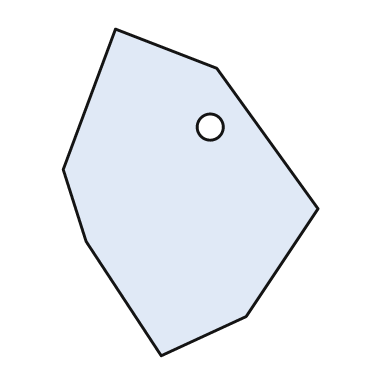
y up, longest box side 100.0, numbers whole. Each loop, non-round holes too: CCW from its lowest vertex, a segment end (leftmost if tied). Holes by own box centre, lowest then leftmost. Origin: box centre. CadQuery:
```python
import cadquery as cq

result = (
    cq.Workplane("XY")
    .moveTo(-9.0, -50.0)
    .lineTo(17.0, -38.0)
    .lineTo(39.0, -5.0)
    .lineTo(8.0, 38.0)
    .lineTo(-23.0, 50.0)
    .lineTo(-39.0, 7.0)
    .lineTo(-32.0, -15.0)
    .close()
    .moveTo(6.0, 20.0)
    .circle(4.0)
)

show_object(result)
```